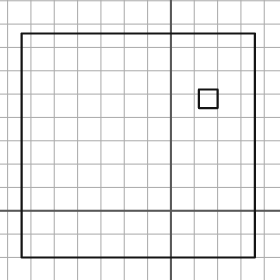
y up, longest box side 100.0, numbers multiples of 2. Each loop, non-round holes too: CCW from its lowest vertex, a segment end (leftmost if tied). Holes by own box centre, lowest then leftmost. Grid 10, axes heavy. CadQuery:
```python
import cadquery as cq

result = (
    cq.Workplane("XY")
    .moveTo(-64.0, -20.0)
    .lineTo(36.0, -20.0)
    .lineTo(36.0, 76.0)
    .lineTo(-64.0, 76.0)
    .close()
    .moveTo(12.0, 44.0)
    .lineTo(20.0, 44.0)
    .lineTo(20.0, 52.0)
    .lineTo(12.0, 52.0)
    .close()
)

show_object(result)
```